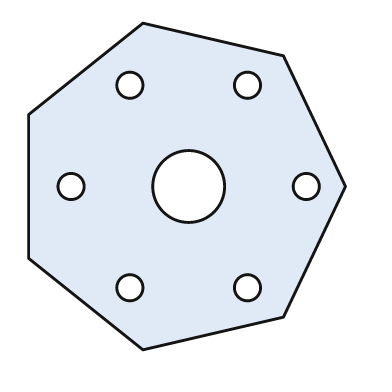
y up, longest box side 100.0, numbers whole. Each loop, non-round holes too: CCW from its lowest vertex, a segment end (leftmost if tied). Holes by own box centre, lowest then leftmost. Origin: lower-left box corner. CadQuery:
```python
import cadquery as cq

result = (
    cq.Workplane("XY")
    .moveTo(35.0, 0.0)
    .lineTo(78.0, 10.0)
    .lineTo(97.0, 50.0)
    .lineTo(78.0, 90.0)
    .lineTo(35.0, 100.0)
    .lineTo(0.0, 72.0)
    .lineTo(0.0, 28.0)
    .close()
    .moveTo(31.0, 19.0)
    .circle(4.0)
    .moveTo(67.0, 19.0)
    .circle(4.0)
    .moveTo(13.0, 50.0)
    .circle(4.0)
    .moveTo(49.0, 50.0)
    .circle(11.0)
    .moveTo(85.0, 50.0)
    .circle(4.0)
    .moveTo(31.0, 81.0)
    .circle(4.0)
    .moveTo(67.0, 81.0)
    .circle(4.0)
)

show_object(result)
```